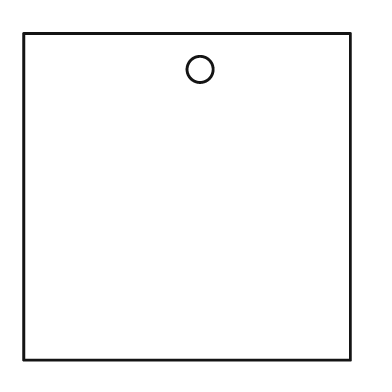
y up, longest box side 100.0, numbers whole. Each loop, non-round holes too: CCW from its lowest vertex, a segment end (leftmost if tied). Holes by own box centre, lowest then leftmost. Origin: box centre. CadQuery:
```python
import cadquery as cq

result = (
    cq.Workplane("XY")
    .moveTo(-50.0, -50.0)
    .lineTo(50.0, -50.0)
    .lineTo(50.0, 50.0)
    .lineTo(-50.0, 50.0)
    .close()
    .moveTo(4.0, 39.0)
    .circle(4.0)
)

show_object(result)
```